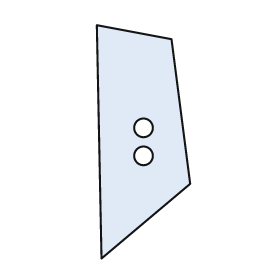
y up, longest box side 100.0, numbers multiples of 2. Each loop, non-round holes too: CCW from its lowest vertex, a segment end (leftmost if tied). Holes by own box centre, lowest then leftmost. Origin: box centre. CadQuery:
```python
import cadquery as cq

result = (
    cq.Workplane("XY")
    .moveTo(-18.0, -50.0)
    .lineTo(20.0, -18.0)
    .lineTo(12.0, 44.0)
    .lineTo(-20.0, 50.0)
    .close()
    .moveTo(0.0, -6.0)
    .circle(4.0)
    .moveTo(0.0, 6.0)
    .circle(4.0)
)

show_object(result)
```